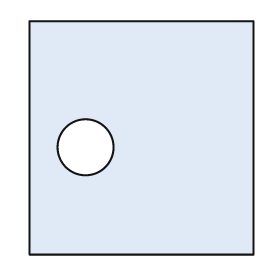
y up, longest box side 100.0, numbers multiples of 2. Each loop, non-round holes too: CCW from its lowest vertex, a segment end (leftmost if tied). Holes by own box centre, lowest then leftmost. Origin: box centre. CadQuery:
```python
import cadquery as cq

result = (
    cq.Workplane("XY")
    .moveTo(-48.0, -50.0)
    .lineTo(48.0, -50.0)
    .lineTo(48.0, 50.0)
    .lineTo(-48.0, 50.0)
    .close()
    .moveTo(-24.0, -4.0)
    .circle(12.0)
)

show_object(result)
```